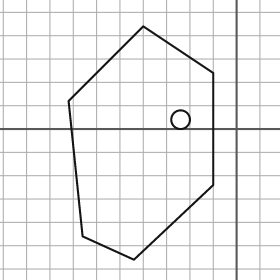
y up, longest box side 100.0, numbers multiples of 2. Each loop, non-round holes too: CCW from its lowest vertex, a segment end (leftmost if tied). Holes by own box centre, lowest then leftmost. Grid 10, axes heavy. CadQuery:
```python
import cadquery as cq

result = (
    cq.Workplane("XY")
    .moveTo(-44.0, -56.0)
    .lineTo(-10.0, -24.0)
    .lineTo(-10.0, 24.0)
    .lineTo(-40.0, 44.0)
    .lineTo(-72.0, 12.0)
    .lineTo(-66.0, -46.0)
    .close()
    .moveTo(-24.0, 4.0)
    .circle(4.0)
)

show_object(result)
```